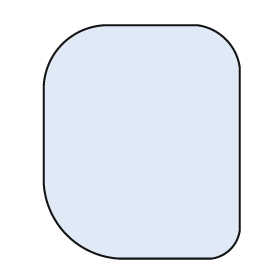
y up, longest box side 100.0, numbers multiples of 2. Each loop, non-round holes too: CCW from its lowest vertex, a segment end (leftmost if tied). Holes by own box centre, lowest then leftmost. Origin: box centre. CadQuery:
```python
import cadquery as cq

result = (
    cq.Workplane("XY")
    .moveTo(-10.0, -50.0)
    .lineTo(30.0, -50.0)
    .threePointArc((38.0, -46.0), (42.0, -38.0))
    .lineTo(42.0, 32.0)
    .threePointArc((36.0, 44.0), (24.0, 50.0))
    .lineTo(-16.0, 50.0)
    .threePointArc((-34.0, 42.0), (-42.0, 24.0))
    .lineTo(-42.0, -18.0)
    .threePointArc((-32.0, -40.0), (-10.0, -50.0))
    .close()
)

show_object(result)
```